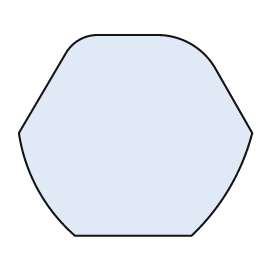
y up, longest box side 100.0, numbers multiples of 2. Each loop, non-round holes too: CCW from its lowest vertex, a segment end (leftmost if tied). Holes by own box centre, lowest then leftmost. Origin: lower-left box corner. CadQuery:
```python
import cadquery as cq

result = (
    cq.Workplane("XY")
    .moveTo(24.0, 0.0)
    .lineTo(74.0, 0.0)
    .threePointArc((90.0, 20.0), (100.0, 44.0))
    .lineTo(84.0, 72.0)
    .threePointArc((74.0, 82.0), (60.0, 86.0))
    .lineTo(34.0, 86.0)
    .threePointArc((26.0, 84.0), (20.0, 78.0))
    .lineTo(0.0, 44.0)
    .threePointArc((8.0, 20.0), (24.0, 0.0))
    .close()
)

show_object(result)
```